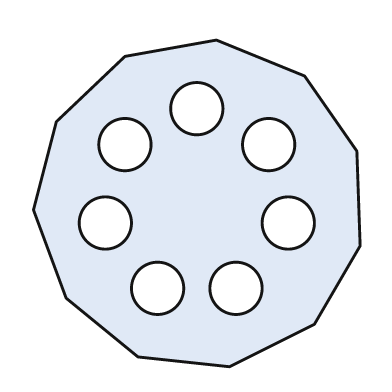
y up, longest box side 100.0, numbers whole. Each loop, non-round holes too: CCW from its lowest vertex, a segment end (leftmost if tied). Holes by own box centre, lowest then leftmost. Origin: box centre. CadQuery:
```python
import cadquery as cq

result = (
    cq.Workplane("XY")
    .moveTo(10.0, -50.0)
    .lineTo(36.0, -37.0)
    .lineTo(50.0, -13.0)
    .lineTo(49.0, 16.0)
    .lineTo(33.0, 39.0)
    .lineTo(6.0, 50.0)
    .lineTo(-22.0, 45.0)
    .lineTo(-43.0, 25.0)
    .lineTo(-50.0, -2.0)
    .lineTo(-40.0, -29.0)
    .lineTo(-18.0, -47.0)
    .close()
    .moveTo(-12.0, -26.0)
    .circle(8.0)
    .moveTo(12.0, -26.0)
    .circle(8.0)
    .moveTo(-28.0, -6.0)
    .circle(8.0)
    .moveTo(28.0, -6.0)
    .circle(8.0)
    .moveTo(-22.0, 18.0)
    .circle(8.0)
    .moveTo(22.0, 18.0)
    .circle(8.0)
    .moveTo(0.0, 29.0)
    .circle(8.0)
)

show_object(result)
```